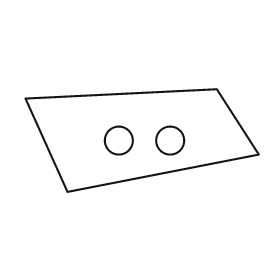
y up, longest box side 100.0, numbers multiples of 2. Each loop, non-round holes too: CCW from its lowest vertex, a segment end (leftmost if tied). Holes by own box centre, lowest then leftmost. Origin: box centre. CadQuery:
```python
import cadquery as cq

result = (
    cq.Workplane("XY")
    .moveTo(-32.0, -22.0)
    .lineTo(50.0, -6.0)
    .lineTo(32.0, 22.0)
    .lineTo(-50.0, 18.0)
    .close()
    .moveTo(-10.0, 0.0)
    .circle(6.0)
    .moveTo(12.0, 0.0)
    .circle(6.0)
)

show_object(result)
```